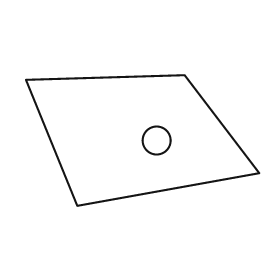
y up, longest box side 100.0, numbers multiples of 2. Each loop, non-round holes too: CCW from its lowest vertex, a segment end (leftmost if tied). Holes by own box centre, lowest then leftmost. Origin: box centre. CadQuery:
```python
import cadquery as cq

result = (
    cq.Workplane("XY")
    .moveTo(-28.0, -28.0)
    .lineTo(50.0, -14.0)
    .lineTo(18.0, 28.0)
    .lineTo(-50.0, 26.0)
    .close()
    .moveTo(6.0, 0.0)
    .circle(6.0)
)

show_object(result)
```